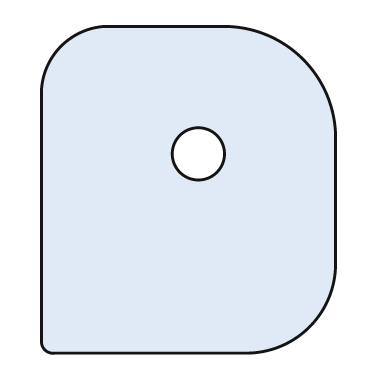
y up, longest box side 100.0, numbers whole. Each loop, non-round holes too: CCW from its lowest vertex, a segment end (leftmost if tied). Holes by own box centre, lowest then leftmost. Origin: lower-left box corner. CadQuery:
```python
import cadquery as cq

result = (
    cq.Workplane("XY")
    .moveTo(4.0, 0.0)
    .lineTo(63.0, 0.0)
    .threePointArc((82.0, 8.0), (90.0, 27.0))
    .lineTo(90.0, 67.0)
    .threePointArc((80.0, 90.0), (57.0, 100.0))
    .lineTo(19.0, 100.0)
    .threePointArc((6.0, 94.0), (0.0, 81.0))
    .lineTo(0.0, 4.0)
    .threePointArc((1.0, 1.0), (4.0, 0.0))
    .close()
    .moveTo(48.0, 61.0)
    .circle(8.0)
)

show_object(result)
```